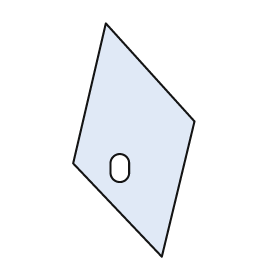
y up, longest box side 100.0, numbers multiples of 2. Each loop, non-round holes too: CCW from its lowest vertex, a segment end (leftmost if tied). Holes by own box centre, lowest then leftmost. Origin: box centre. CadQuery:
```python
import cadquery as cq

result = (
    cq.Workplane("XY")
    .moveTo(12.0, -50.0)
    .lineTo(26.0, 8.0)
    .lineTo(-12.0, 50.0)
    .lineTo(-26.0, -10.0)
    .close()
    .moveTo(-10.0, -14.0)
    .threePointArc((-6.0, -18.0), (-2.0, -14.0))
    .lineTo(-2.0, -10.0)
    .threePointArc((-6.0, -6.0), (-10.0, -10.0))
    .close()
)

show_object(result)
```